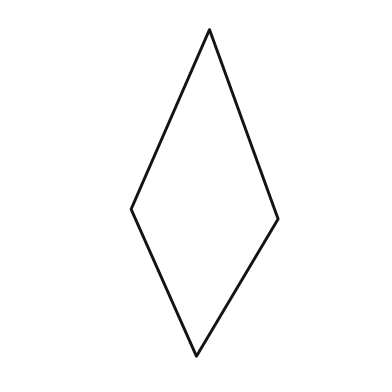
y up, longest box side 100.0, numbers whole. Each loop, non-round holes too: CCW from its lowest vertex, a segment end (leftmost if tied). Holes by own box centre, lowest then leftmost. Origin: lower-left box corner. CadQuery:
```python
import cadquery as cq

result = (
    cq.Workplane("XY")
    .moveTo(20.0, 0.0)
    .lineTo(45.0, 42.0)
    .lineTo(24.0, 100.0)
    .lineTo(0.0, 45.0)
    .close()
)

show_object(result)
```